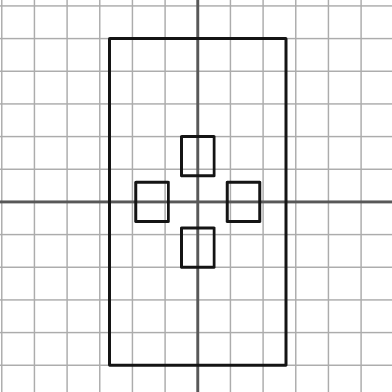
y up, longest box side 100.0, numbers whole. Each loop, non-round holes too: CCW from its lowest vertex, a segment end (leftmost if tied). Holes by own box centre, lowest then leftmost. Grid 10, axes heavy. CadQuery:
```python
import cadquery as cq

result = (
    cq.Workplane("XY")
    .moveTo(-27.0, -50.0)
    .lineTo(27.0, -50.0)
    .lineTo(27.0, 50.0)
    .lineTo(-27.0, 50.0)
    .close()
    .moveTo(-5.0, -20.0)
    .lineTo(5.0, -20.0)
    .lineTo(5.0, -8.0)
    .lineTo(-5.0, -8.0)
    .close()
    .moveTo(-19.0, -6.0)
    .lineTo(-9.0, -6.0)
    .lineTo(-9.0, 6.0)
    .lineTo(-19.0, 6.0)
    .close()
    .moveTo(9.0, -6.0)
    .lineTo(19.0, -6.0)
    .lineTo(19.0, 6.0)
    .lineTo(9.0, 6.0)
    .close()
    .moveTo(-5.0, 8.0)
    .lineTo(5.0, 8.0)
    .lineTo(5.0, 20.0)
    .lineTo(-5.0, 20.0)
    .close()
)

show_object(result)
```